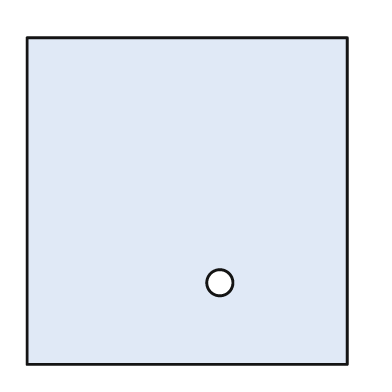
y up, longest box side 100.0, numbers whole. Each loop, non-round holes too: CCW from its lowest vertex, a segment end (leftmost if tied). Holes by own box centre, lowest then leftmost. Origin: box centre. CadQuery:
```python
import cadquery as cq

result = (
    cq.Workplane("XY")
    .moveTo(-49.0, -50.0)
    .lineTo(49.0, -50.0)
    .lineTo(49.0, 50.0)
    .lineTo(-49.0, 50.0)
    .close()
    .moveTo(10.0, -25.0)
    .circle(4.0)
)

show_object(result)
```